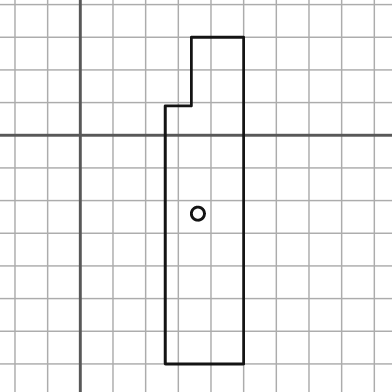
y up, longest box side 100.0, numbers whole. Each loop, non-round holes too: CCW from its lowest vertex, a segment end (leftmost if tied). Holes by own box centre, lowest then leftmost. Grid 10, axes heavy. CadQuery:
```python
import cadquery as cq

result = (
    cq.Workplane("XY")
    .moveTo(26.0, -70.0)
    .lineTo(50.0, -70.0)
    .lineTo(50.0, 30.0)
    .lineTo(34.0, 30.0)
    .lineTo(34.0, 9.0)
    .lineTo(26.0, 9.0)
    .close()
    .moveTo(36.0, -24.0)
    .circle(2.0)
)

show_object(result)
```